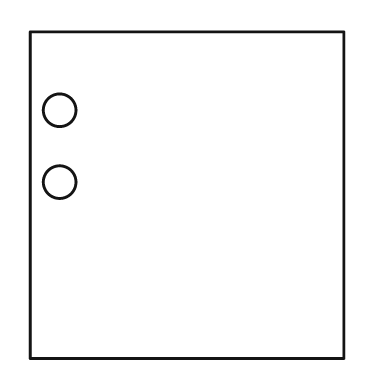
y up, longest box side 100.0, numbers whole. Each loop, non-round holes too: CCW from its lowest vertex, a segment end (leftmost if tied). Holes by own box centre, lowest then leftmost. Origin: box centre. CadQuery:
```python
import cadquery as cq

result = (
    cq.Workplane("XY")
    .moveTo(-48.0, -50.0)
    .lineTo(48.0, -50.0)
    .lineTo(48.0, 50.0)
    .lineTo(-48.0, 50.0)
    .close()
    .moveTo(-39.0, 4.0)
    .circle(5.0)
    .moveTo(-39.0, 26.0)
    .circle(5.0)
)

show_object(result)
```